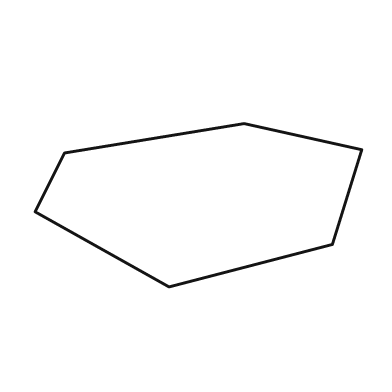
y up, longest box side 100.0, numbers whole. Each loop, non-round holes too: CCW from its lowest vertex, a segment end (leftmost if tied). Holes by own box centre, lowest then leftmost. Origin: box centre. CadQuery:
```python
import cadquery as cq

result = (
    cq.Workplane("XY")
    .moveTo(-9.0, -25.0)
    .lineTo(41.0, -12.0)
    .lineTo(50.0, 17.0)
    .lineTo(14.0, 25.0)
    .lineTo(-41.0, 16.0)
    .lineTo(-50.0, -2.0)
    .close()
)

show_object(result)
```